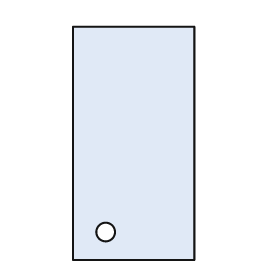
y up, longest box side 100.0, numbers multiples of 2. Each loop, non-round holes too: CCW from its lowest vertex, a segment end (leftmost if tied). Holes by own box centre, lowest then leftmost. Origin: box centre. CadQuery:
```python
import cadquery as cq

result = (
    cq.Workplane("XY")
    .moveTo(-26.0, -50.0)
    .lineTo(26.0, -50.0)
    .lineTo(26.0, 50.0)
    .lineTo(-26.0, 50.0)
    .close()
    .moveTo(-12.0, -38.0)
    .circle(4.0)
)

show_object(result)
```